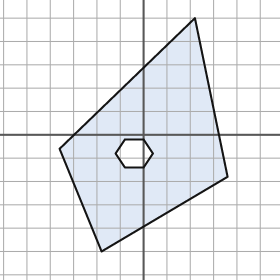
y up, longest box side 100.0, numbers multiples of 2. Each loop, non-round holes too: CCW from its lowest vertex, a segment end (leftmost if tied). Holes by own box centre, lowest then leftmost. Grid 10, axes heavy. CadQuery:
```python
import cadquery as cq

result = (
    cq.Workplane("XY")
    .moveTo(-18.0, -50.0)
    .lineTo(36.0, -18.0)
    .lineTo(22.0, 50.0)
    .lineTo(-36.0, -6.0)
    .close()
    .moveTo(-8.0, -14.0)
    .lineTo(0.0, -14.0)
    .lineTo(4.0, -8.0)
    .lineTo(0.0, -2.0)
    .lineTo(-8.0, -2.0)
    .lineTo(-12.0, -8.0)
    .close()
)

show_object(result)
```